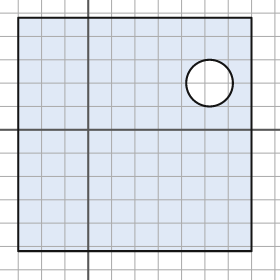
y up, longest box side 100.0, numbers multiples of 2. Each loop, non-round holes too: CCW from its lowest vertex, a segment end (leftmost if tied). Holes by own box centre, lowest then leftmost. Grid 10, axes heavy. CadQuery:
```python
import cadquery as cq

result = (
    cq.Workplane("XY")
    .moveTo(-30.0, -52.0)
    .lineTo(70.0, -52.0)
    .lineTo(70.0, 48.0)
    .lineTo(-30.0, 48.0)
    .close()
    .moveTo(52.0, 20.0)
    .circle(10.0)
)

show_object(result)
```